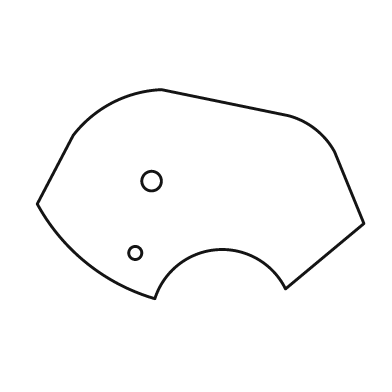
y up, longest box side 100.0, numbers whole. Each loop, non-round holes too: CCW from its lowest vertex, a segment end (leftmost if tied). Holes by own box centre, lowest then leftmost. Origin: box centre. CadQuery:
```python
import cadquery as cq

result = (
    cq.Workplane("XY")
    .moveTo(-14.0, -32.0)
    .threePointArc((5.0, -17.0), (26.0, -29.0))
    .lineTo(50.0, -9.0)
    .lineTo(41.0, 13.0)
    .threePointArc((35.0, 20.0), (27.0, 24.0))
    .lineTo(-12.0, 32.0)
    .threePointArc((-27.0, 28.0), (-39.0, 18.0))
    .lineTo(-50.0, -3.0)
    .threePointArc((-35.0, -21.0), (-14.0, -32.0))
    .close()
    .moveTo(-20.0, -18.0)
    .circle(2.0)
    .moveTo(-15.0, 4.0)
    .circle(3.0)
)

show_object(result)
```